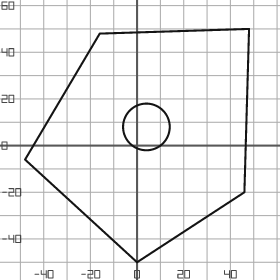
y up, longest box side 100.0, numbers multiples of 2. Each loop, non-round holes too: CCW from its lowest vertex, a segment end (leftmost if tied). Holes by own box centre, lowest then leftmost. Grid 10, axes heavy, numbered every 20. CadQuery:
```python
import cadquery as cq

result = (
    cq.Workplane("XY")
    .moveTo(0.0, -50.0)
    .lineTo(46.0, -20.0)
    .lineTo(48.0, 50.0)
    .lineTo(-16.0, 48.0)
    .lineTo(-48.0, -6.0)
    .close()
    .moveTo(4.0, 8.0)
    .circle(10.0)
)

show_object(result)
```